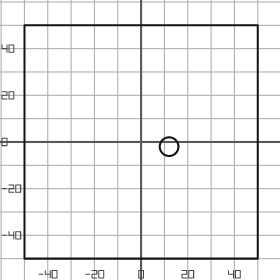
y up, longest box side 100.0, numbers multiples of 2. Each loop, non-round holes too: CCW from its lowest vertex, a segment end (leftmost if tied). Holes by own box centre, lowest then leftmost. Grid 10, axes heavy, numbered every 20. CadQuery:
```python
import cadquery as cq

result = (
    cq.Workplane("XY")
    .moveTo(-50.0, -50.0)
    .lineTo(50.0, -50.0)
    .lineTo(50.0, 50.0)
    .lineTo(-50.0, 50.0)
    .close()
    .moveTo(12.0, -2.0)
    .circle(4.0)
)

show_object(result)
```